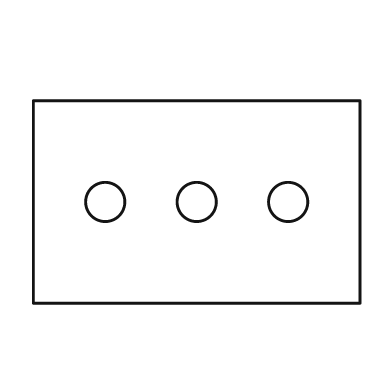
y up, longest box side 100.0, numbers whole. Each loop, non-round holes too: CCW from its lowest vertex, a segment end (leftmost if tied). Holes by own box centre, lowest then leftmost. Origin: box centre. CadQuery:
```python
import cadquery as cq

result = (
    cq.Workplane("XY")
    .moveTo(-50.0, -31.0)
    .lineTo(50.0, -31.0)
    .lineTo(50.0, 31.0)
    .lineTo(-50.0, 31.0)
    .close()
    .moveTo(-28.0, 0.0)
    .circle(6.0)
    .moveTo(0.0, 0.0)
    .circle(6.0)
    .moveTo(28.0, 0.0)
    .circle(6.0)
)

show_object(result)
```